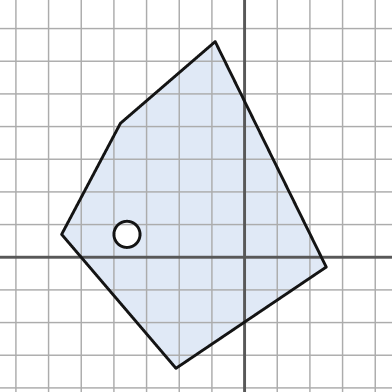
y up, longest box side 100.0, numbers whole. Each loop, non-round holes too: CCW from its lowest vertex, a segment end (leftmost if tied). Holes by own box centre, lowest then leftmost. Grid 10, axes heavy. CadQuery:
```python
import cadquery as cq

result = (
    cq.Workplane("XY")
    .moveTo(-21.0, -34.0)
    .lineTo(25.0, -3.0)
    .lineTo(-9.0, 66.0)
    .lineTo(-38.0, 41.0)
    .lineTo(-56.0, 7.0)
    .close()
    .moveTo(-36.0, 7.0)
    .circle(4.0)
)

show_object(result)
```